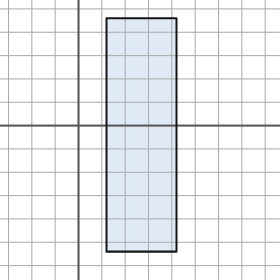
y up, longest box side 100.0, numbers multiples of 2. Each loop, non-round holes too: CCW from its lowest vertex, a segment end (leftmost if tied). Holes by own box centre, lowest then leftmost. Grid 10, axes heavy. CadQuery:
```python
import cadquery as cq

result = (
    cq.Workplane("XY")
    .moveTo(12.0, -54.0)
    .lineTo(42.0, -54.0)
    .lineTo(42.0, 46.0)
    .lineTo(12.0, 46.0)
    .close()
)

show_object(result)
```